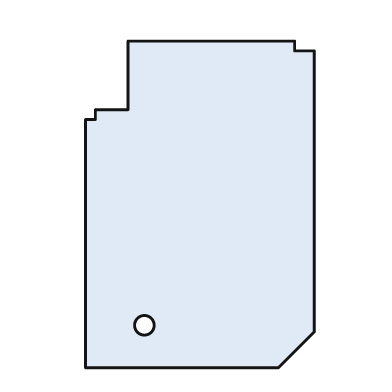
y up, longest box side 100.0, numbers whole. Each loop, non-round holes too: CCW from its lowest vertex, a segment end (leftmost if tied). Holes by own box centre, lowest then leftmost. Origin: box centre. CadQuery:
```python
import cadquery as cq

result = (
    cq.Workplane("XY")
    .moveTo(-35.0, -50.0)
    .lineTo(24.0, -50.0)
    .lineTo(35.0, -39.0)
    .lineTo(35.0, 47.0)
    .lineTo(29.0, 47.0)
    .lineTo(29.0, 50.0)
    .lineTo(-22.0, 50.0)
    .lineTo(-22.0, 29.0)
    .lineTo(-32.0, 29.0)
    .lineTo(-32.0, 26.0)
    .lineTo(-35.0, 26.0)
    .close()
    .moveTo(-17.0, -37.0)
    .circle(3.0)
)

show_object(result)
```